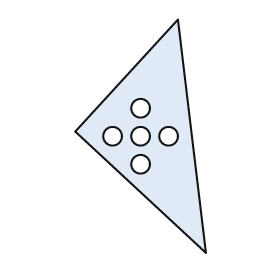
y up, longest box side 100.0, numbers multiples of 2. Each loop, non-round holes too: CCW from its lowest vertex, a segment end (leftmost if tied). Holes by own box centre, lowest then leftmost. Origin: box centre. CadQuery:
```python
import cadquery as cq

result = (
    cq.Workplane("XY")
    .moveTo(28.0, -50.0)
    .lineTo(16.0, 50.0)
    .lineTo(-28.0, 2.0)
    .close()
    .moveTo(0.0, -12.0)
    .circle(4.0)
    .moveTo(-12.0, 0.0)
    .circle(4.0)
    .moveTo(0.0, 0.0)
    .circle(4.0)
    .moveTo(12.0, 0.0)
    .circle(4.0)
    .moveTo(0.0, 12.0)
    .circle(4.0)
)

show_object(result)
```